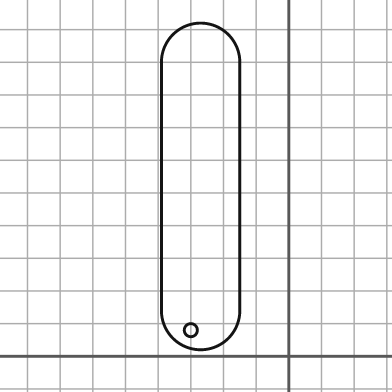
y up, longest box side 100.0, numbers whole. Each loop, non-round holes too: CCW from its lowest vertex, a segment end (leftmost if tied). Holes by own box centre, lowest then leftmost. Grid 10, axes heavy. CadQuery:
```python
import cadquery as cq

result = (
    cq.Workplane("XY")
    .moveTo(-39.0, 14.0)
    .threePointArc((-27.0, 2.0), (-15.0, 14.0))
    .lineTo(-15.0, 90.0)
    .threePointArc((-27.0, 102.0), (-39.0, 90.0))
    .close()
    .moveTo(-30.0, 8.0)
    .circle(2.0)
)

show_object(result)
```